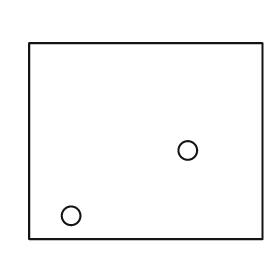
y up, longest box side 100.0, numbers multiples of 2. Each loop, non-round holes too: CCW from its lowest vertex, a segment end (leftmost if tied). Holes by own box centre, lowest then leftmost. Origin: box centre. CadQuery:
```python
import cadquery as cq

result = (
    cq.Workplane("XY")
    .moveTo(-50.0, -42.0)
    .lineTo(50.0, -42.0)
    .lineTo(50.0, 42.0)
    .lineTo(-50.0, 42.0)
    .close()
    .moveTo(-32.0, -32.0)
    .circle(4.0)
    .moveTo(18.0, -4.0)
    .circle(4.0)
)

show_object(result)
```